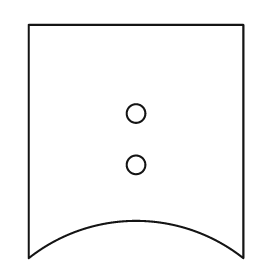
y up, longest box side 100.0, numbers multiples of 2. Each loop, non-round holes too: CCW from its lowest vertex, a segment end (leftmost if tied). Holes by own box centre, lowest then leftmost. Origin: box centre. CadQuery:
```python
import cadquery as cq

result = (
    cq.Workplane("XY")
    .moveTo(-46.0, -50.0)
    .threePointArc((0.0, -34.0), (46.0, -50.0))
    .lineTo(46.0, 50.0)
    .lineTo(-46.0, 50.0)
    .close()
    .moveTo(0.0, -10.0)
    .circle(4.0)
    .moveTo(0.0, 12.0)
    .circle(4.0)
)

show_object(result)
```